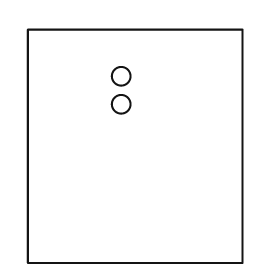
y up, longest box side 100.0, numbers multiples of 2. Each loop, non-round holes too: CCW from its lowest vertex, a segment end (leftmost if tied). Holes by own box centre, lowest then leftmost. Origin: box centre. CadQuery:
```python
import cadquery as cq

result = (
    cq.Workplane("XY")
    .moveTo(-46.0, -50.0)
    .lineTo(46.0, -50.0)
    .lineTo(46.0, 50.0)
    .lineTo(-46.0, 50.0)
    .close()
    .moveTo(-6.0, 18.0)
    .circle(4.0)
    .moveTo(-6.0, 30.0)
    .circle(4.0)
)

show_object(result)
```